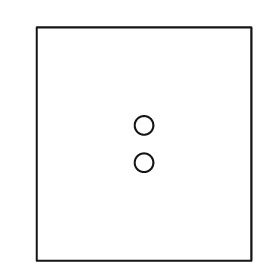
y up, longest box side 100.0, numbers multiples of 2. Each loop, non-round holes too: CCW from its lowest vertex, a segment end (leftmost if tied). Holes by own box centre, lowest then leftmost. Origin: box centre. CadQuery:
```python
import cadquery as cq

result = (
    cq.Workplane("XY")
    .moveTo(-46.0, -50.0)
    .lineTo(46.0, -50.0)
    .lineTo(46.0, 50.0)
    .lineTo(-46.0, 50.0)
    .close()
    .moveTo(0.0, -8.0)
    .circle(4.0)
    .moveTo(0.0, 8.0)
    .circle(4.0)
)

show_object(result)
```